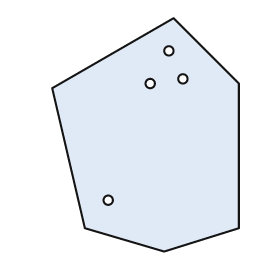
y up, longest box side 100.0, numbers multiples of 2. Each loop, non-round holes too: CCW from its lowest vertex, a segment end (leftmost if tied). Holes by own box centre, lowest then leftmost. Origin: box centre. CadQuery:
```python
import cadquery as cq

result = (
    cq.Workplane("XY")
    .moveTo(8.0, -50.0)
    .lineTo(40.0, -40.0)
    .lineTo(40.0, 22.0)
    .lineTo(12.0, 50.0)
    .lineTo(-40.0, 20.0)
    .lineTo(-26.0, -40.0)
    .close()
    .moveTo(-16.0, -28.0)
    .circle(2.0)
    .moveTo(2.0, 22.0)
    .circle(2.0)
    .moveTo(16.0, 24.0)
    .circle(2.0)
    .moveTo(10.0, 36.0)
    .circle(2.0)
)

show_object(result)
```